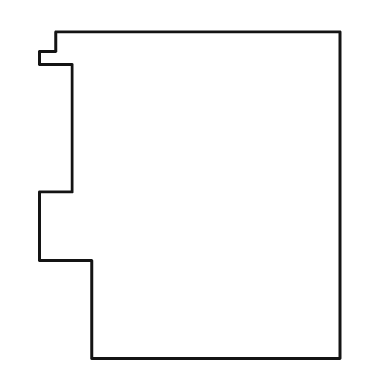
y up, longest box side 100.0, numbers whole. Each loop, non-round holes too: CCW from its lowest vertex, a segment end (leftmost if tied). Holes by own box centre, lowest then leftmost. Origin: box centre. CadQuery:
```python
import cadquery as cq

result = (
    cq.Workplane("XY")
    .moveTo(-30.0, -50.0)
    .lineTo(46.0, -50.0)
    .lineTo(46.0, 50.0)
    .lineTo(-41.0, 50.0)
    .lineTo(-41.0, 44.0)
    .lineTo(-46.0, 44.0)
    .lineTo(-46.0, 40.0)
    .lineTo(-36.0, 40.0)
    .lineTo(-36.0, 1.0)
    .lineTo(-46.0, 1.0)
    .lineTo(-46.0, -20.0)
    .lineTo(-30.0, -20.0)
    .close()
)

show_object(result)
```